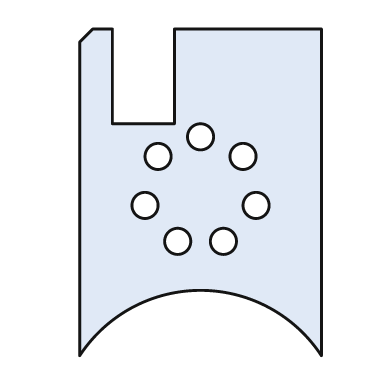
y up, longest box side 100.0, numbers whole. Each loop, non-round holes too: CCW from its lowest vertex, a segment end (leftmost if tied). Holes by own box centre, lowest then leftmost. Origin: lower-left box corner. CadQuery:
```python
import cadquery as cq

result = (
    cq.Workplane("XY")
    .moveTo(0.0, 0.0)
    .threePointArc((37.0, 20.0), (74.0, 0.0))
    .lineTo(74.0, 100.0)
    .lineTo(29.0, 100.0)
    .lineTo(29.0, 71.0)
    .lineTo(10.0, 71.0)
    .lineTo(10.0, 100.0)
    .lineTo(4.0, 100.0)
    .lineTo(0.0, 96.0)
    .close()
    .moveTo(30.0, 35.0)
    .circle(4.0)
    .moveTo(44.0, 35.0)
    .circle(4.0)
    .moveTo(20.0, 46.0)
    .circle(4.0)
    .moveTo(54.0, 46.0)
    .circle(4.0)
    .moveTo(24.0, 61.0)
    .circle(4.0)
    .moveTo(50.0, 61.0)
    .circle(4.0)
    .moveTo(37.0, 67.0)
    .circle(4.0)
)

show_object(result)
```